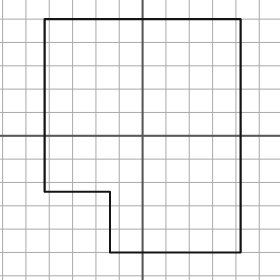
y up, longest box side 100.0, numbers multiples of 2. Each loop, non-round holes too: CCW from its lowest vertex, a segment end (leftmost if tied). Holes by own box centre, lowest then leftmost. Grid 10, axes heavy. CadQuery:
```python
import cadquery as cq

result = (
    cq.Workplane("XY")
    .moveTo(-14.0, -50.0)
    .lineTo(42.0, -50.0)
    .lineTo(42.0, 50.0)
    .lineTo(-42.0, 50.0)
    .lineTo(-42.0, -24.0)
    .lineTo(-14.0, -24.0)
    .close()
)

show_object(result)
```